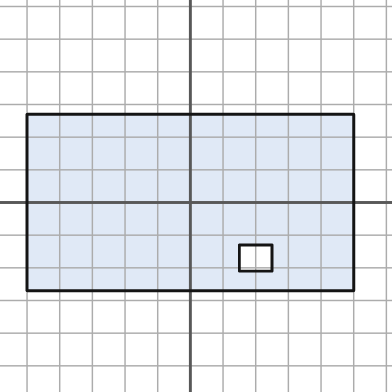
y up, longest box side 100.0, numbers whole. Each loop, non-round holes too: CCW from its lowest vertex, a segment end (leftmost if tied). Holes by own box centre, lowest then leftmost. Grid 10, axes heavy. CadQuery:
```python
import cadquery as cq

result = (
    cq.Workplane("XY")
    .moveTo(-50.0, -27.0)
    .lineTo(50.0, -27.0)
    .lineTo(50.0, 27.0)
    .lineTo(-50.0, 27.0)
    .close()
    .moveTo(15.0, -21.0)
    .lineTo(25.0, -21.0)
    .lineTo(25.0, -13.0)
    .lineTo(15.0, -13.0)
    .close()
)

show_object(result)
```